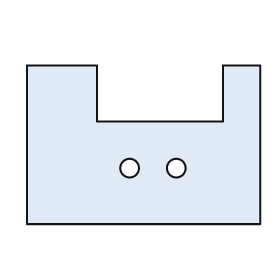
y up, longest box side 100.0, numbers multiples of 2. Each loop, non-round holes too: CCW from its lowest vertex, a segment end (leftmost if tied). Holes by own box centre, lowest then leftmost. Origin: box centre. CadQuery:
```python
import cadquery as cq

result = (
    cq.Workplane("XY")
    .moveTo(-50.0, -34.0)
    .lineTo(50.0, -34.0)
    .lineTo(50.0, 34.0)
    .lineTo(34.0, 34.0)
    .lineTo(34.0, 10.0)
    .lineTo(-20.0, 10.0)
    .lineTo(-20.0, 34.0)
    .lineTo(-50.0, 34.0)
    .close()
    .moveTo(-6.0, -10.0)
    .circle(4.0)
    .moveTo(14.0, -10.0)
    .circle(4.0)
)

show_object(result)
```